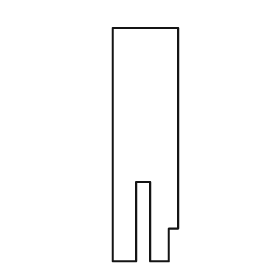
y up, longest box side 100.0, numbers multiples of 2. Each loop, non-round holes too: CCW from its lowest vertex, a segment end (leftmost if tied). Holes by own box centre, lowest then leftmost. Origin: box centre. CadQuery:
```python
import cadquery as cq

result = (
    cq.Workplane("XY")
    .moveTo(-14.0, -50.0)
    .lineTo(-4.0, -50.0)
    .lineTo(-4.0, -16.0)
    .lineTo(2.0, -16.0)
    .lineTo(2.0, -50.0)
    .lineTo(10.0, -50.0)
    .lineTo(10.0, -36.0)
    .lineTo(14.0, -36.0)
    .lineTo(14.0, 50.0)
    .lineTo(-14.0, 50.0)
    .close()
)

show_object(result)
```